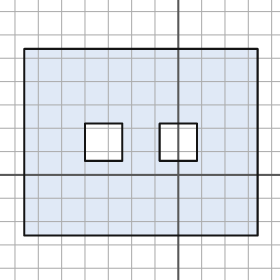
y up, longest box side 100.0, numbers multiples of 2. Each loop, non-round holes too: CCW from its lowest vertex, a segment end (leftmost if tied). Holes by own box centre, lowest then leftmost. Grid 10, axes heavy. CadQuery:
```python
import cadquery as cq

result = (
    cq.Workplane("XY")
    .moveTo(-66.0, -26.0)
    .lineTo(34.0, -26.0)
    .lineTo(34.0, 54.0)
    .lineTo(-66.0, 54.0)
    .close()
    .moveTo(-40.0, 6.0)
    .lineTo(-24.0, 6.0)
    .lineTo(-24.0, 22.0)
    .lineTo(-40.0, 22.0)
    .close()
    .moveTo(-8.0, 6.0)
    .lineTo(8.0, 6.0)
    .lineTo(8.0, 22.0)
    .lineTo(-8.0, 22.0)
    .close()
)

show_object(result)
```